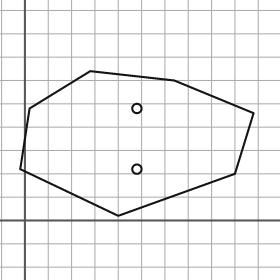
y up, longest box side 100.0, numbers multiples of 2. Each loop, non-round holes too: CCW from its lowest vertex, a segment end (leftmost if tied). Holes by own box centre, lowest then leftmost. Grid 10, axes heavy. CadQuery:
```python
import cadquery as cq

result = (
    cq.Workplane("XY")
    .moveTo(40.0, 2.0)
    .lineTo(90.0, 20.0)
    .lineTo(98.0, 46.0)
    .lineTo(64.0, 60.0)
    .lineTo(28.0, 64.0)
    .lineTo(2.0, 48.0)
    .lineTo(-2.0, 22.0)
    .close()
    .moveTo(48.0, 22.0)
    .circle(2.0)
    .moveTo(48.0, 48.0)
    .circle(2.0)
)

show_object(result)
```